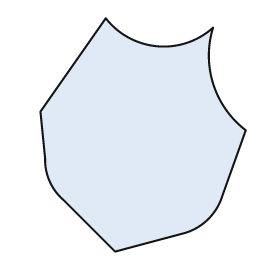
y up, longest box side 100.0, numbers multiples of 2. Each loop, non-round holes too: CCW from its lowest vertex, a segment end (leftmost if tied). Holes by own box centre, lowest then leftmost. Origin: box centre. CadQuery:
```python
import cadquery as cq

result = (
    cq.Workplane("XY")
    .moveTo(-12.0, -50.0)
    .lineTo(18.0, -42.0)
    .threePointArc((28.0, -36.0), (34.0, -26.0))
    .lineTo(44.0, 2.0)
    .threePointArc((30.0, 22.0), (30.0, 46.0))
    .threePointArc((6.0, 38.0), (-16.0, 50.0))
    .lineTo(-44.0, 10.0)
    .lineTo(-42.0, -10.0)
    .threePointArc((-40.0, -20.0), (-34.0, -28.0))
    .close()
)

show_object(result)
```